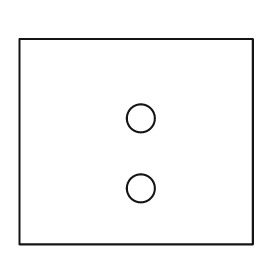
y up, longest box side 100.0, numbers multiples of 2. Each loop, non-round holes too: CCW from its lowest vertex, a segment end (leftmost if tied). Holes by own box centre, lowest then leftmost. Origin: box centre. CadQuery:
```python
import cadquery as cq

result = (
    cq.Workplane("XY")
    .moveTo(-50.0, -44.0)
    .lineTo(50.0, -44.0)
    .lineTo(50.0, 44.0)
    .lineTo(-50.0, 44.0)
    .close()
    .moveTo(2.0, -20.0)
    .circle(6.0)
    .moveTo(2.0, 10.0)
    .circle(6.0)
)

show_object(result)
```